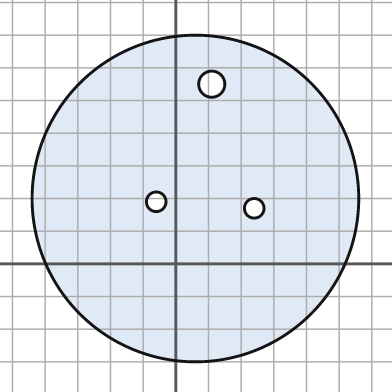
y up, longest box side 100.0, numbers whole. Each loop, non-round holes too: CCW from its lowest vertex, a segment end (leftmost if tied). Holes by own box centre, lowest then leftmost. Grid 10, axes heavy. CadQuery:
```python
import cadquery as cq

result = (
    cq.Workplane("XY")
    .moveTo(6.0, 20.0)
    .circle(50.0)
    .moveTo(24.0, 17.0)
    .circle(3.0)
    .moveTo(-6.0, 19.0)
    .circle(3.0)
    .moveTo(11.0, 55.0)
    .circle(4.0)
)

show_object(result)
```